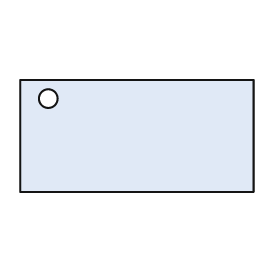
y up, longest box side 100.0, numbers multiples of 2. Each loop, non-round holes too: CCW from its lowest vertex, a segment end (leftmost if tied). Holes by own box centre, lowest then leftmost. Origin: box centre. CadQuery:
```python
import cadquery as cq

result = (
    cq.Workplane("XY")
    .moveTo(-50.0, -24.0)
    .lineTo(50.0, -24.0)
    .lineTo(50.0, 24.0)
    .lineTo(-50.0, 24.0)
    .close()
    .moveTo(-38.0, 16.0)
    .circle(4.0)
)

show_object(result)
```